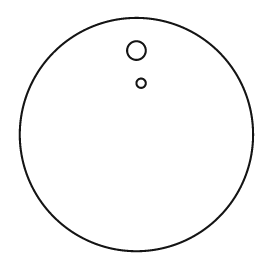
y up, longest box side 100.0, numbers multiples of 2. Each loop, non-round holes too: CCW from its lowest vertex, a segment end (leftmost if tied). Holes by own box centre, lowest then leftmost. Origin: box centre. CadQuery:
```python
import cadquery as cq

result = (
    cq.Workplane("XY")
    .moveTo(0.0, 0.0)
    .circle(50.0)
    .moveTo(2.0, 22.0)
    .circle(2.0)
    .moveTo(0.0, 36.0)
    .circle(4.0)
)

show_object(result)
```